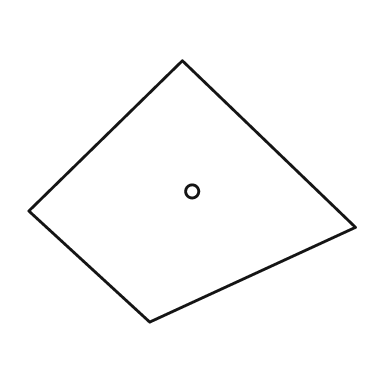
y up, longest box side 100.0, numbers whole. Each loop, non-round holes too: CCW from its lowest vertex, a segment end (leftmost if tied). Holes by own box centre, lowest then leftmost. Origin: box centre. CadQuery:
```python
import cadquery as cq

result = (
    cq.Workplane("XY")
    .moveTo(-13.0, -40.0)
    .lineTo(50.0, -11.0)
    .lineTo(-3.0, 40.0)
    .lineTo(-50.0, -6.0)
    .close()
    .moveTo(0.0, 0.0)
    .circle(2.0)
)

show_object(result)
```